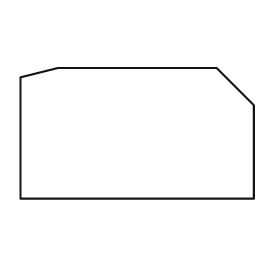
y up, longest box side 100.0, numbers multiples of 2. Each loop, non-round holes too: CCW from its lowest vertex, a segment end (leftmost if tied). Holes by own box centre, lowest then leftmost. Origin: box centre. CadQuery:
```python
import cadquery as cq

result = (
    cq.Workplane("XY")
    .moveTo(-50.0, -28.0)
    .lineTo(50.0, -28.0)
    .lineTo(50.0, 12.0)
    .lineTo(34.0, 28.0)
    .lineTo(-34.0, 28.0)
    .lineTo(-50.0, 24.0)
    .close()
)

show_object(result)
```